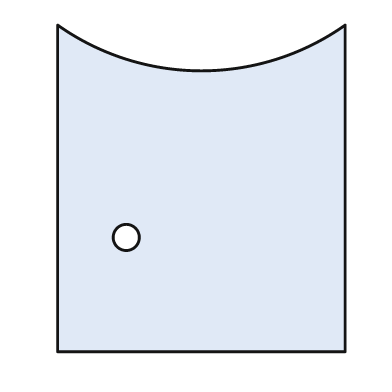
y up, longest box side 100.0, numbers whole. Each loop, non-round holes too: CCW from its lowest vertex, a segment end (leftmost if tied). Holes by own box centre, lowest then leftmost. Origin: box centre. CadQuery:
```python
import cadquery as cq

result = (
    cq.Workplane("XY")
    .moveTo(-44.0, -50.0)
    .lineTo(44.0, -50.0)
    .lineTo(44.0, 50.0)
    .threePointArc((0.0, 36.0), (-44.0, 50.0))
    .close()
    .moveTo(-23.0, -15.0)
    .circle(4.0)
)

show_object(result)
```